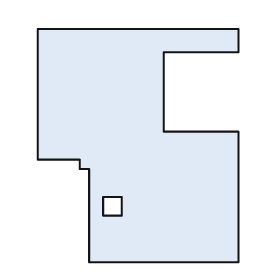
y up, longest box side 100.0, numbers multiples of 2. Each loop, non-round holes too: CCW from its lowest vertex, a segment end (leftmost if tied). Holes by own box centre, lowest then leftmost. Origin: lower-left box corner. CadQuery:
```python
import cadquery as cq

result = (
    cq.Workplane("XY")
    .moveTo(22.0, 0.0)
    .lineTo(86.0, 0.0)
    .lineTo(86.0, 56.0)
    .lineTo(54.0, 56.0)
    .lineTo(54.0, 90.0)
    .lineTo(86.0, 90.0)
    .lineTo(86.0, 100.0)
    .lineTo(0.0, 100.0)
    .lineTo(0.0, 44.0)
    .lineTo(18.0, 44.0)
    .lineTo(18.0, 40.0)
    .lineTo(22.0, 40.0)
    .close()
    .moveTo(28.0, 20.0)
    .lineTo(36.0, 20.0)
    .lineTo(36.0, 28.0)
    .lineTo(28.0, 28.0)
    .close()
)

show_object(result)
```